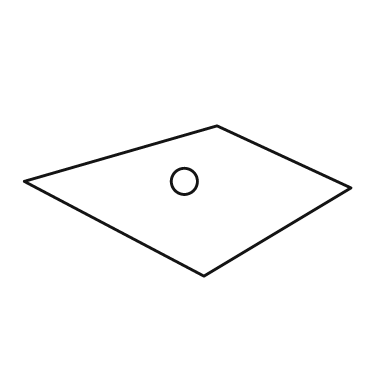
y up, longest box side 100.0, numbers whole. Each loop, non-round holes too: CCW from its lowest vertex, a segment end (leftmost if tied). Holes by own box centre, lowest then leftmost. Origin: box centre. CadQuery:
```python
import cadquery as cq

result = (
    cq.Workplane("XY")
    .moveTo(5.0, -23.0)
    .lineTo(50.0, 4.0)
    .lineTo(9.0, 23.0)
    .lineTo(-50.0, 6.0)
    .close()
    .moveTo(-1.0, 6.0)
    .circle(4.0)
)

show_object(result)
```